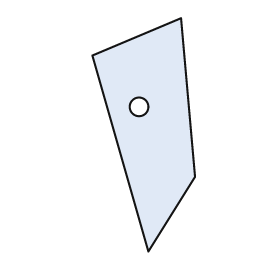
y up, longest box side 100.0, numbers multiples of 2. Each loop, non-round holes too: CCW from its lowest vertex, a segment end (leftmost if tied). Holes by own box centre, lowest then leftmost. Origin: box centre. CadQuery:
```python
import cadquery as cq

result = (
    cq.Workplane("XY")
    .moveTo(2.0, -50.0)
    .lineTo(22.0, -18.0)
    .lineTo(16.0, 50.0)
    .lineTo(-22.0, 34.0)
    .close()
    .moveTo(-2.0, 12.0)
    .circle(4.0)
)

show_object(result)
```